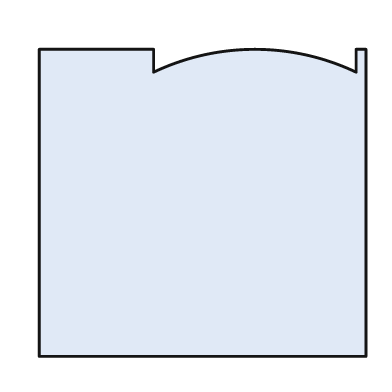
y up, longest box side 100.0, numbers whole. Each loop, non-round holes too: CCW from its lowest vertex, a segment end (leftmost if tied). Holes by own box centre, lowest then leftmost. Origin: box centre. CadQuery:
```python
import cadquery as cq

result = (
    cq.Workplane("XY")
    .moveTo(-50.0, -47.0)
    .lineTo(50.0, -47.0)
    .lineTo(50.0, 47.0)
    .lineTo(47.0, 47.0)
    .lineTo(47.0, 40.0)
    .threePointArc((16.0, 47.0), (-15.0, 40.0))
    .lineTo(-15.0, 47.0)
    .lineTo(-50.0, 47.0)
    .close()
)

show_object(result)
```